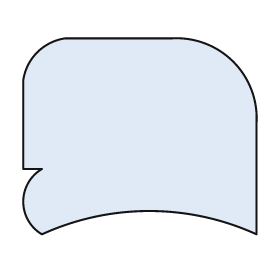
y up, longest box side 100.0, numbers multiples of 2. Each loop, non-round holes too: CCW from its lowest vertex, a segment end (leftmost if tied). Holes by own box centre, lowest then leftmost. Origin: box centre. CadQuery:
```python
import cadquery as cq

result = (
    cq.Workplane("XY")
    .moveTo(-42.0, -42.0)
    .threePointArc((4.0, -32.0), (50.0, -42.0))
    .lineTo(50.0, 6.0)
    .threePointArc((40.0, 32.0), (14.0, 42.0))
    .lineTo(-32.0, 42.0)
    .threePointArc((-44.0, 36.0), (-50.0, 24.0))
    .lineTo(-50.0, -14.0)
    .lineTo(-42.0, -14.0)
    .threePointArc((-50.0, -28.0), (-42.0, -42.0))
    .close()
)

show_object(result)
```